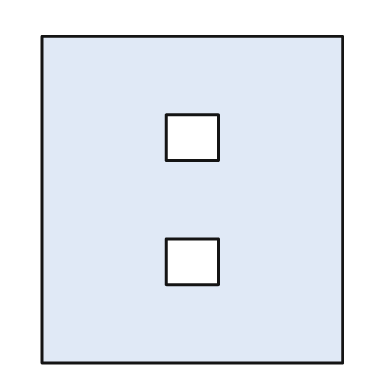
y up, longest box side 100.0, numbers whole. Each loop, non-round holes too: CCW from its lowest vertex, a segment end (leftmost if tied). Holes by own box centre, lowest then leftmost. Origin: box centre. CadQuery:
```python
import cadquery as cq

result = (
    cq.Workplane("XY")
    .moveTo(-46.0, -50.0)
    .lineTo(46.0, -50.0)
    .lineTo(46.0, 50.0)
    .lineTo(-46.0, 50.0)
    .close()
    .moveTo(-8.0, -26.0)
    .lineTo(8.0, -26.0)
    .lineTo(8.0, -12.0)
    .lineTo(-8.0, -12.0)
    .close()
    .moveTo(-8.0, 12.0)
    .lineTo(8.0, 12.0)
    .lineTo(8.0, 26.0)
    .lineTo(-8.0, 26.0)
    .close()
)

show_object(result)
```